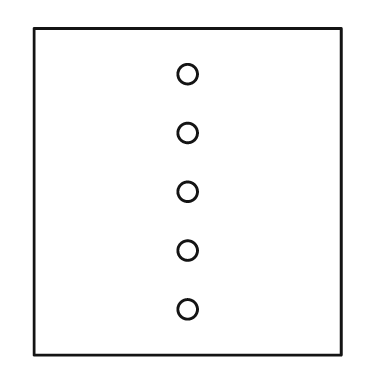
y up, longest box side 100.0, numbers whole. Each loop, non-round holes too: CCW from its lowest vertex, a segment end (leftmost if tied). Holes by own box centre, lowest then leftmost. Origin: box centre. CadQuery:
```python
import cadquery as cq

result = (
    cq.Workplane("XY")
    .moveTo(-47.0, -50.0)
    .lineTo(47.0, -50.0)
    .lineTo(47.0, 50.0)
    .lineTo(-47.0, 50.0)
    .close()
    .moveTo(0.0, -36.0)
    .circle(3.0)
    .moveTo(0.0, -18.0)
    .circle(3.0)
    .moveTo(0.0, 0.0)
    .circle(3.0)
    .moveTo(0.0, 18.0)
    .circle(3.0)
    .moveTo(0.0, 36.0)
    .circle(3.0)
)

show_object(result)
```